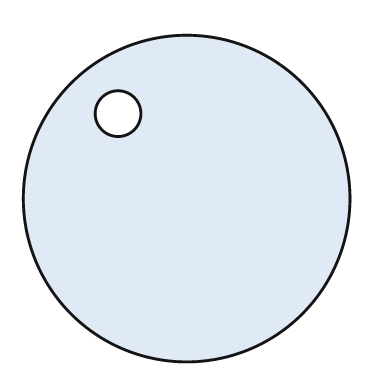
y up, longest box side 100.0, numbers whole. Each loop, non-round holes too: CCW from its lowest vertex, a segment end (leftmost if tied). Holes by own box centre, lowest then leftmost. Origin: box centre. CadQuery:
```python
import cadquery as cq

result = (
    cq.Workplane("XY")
    .moveTo(0.0, 0.0)
    .circle(50.0)
    .moveTo(-21.0, 26.0)
    .circle(7.0)
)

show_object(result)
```